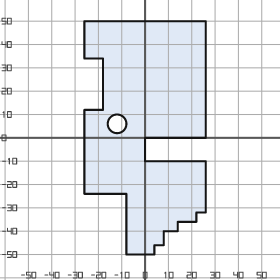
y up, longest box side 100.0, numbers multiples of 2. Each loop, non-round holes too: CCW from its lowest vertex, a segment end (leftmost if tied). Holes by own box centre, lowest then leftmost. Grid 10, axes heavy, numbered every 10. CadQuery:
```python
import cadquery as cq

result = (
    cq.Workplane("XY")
    .moveTo(-8.0, -50.0)
    .lineTo(4.0, -50.0)
    .lineTo(4.0, -46.0)
    .lineTo(8.0, -46.0)
    .lineTo(8.0, -40.0)
    .lineTo(14.0, -40.0)
    .lineTo(14.0, -36.0)
    .lineTo(22.0, -36.0)
    .lineTo(22.0, -32.0)
    .lineTo(26.0, -32.0)
    .lineTo(26.0, -10.0)
    .lineTo(0.0, -10.0)
    .lineTo(0.0, 0.0)
    .lineTo(26.0, 0.0)
    .lineTo(26.0, 50.0)
    .lineTo(-26.0, 50.0)
    .lineTo(-26.0, 34.0)
    .lineTo(-18.0, 34.0)
    .lineTo(-18.0, 12.0)
    .lineTo(-26.0, 12.0)
    .lineTo(-26.0, -24.0)
    .lineTo(-8.0, -24.0)
    .close()
    .moveTo(-12.0, 6.0)
    .circle(4.0)
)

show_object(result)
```